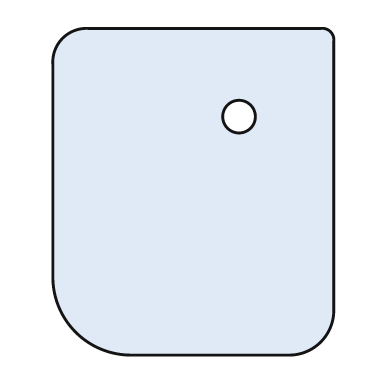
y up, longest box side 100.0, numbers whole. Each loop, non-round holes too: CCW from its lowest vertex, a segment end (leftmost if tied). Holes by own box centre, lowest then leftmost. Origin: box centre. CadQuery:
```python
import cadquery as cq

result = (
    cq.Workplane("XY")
    .moveTo(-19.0, -50.0)
    .lineTo(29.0, -50.0)
    .threePointArc((39.0, -46.0), (43.0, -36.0))
    .lineTo(43.0, 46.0)
    .threePointArc((42.0, 49.0), (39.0, 50.0))
    .lineTo(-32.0, 50.0)
    .threePointArc((-40.0, 47.0), (-43.0, 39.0))
    .lineTo(-43.0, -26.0)
    .threePointArc((-36.0, -43.0), (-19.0, -50.0))
    .close()
    .moveTo(14.0, 23.0)
    .circle(5.0)
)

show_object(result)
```